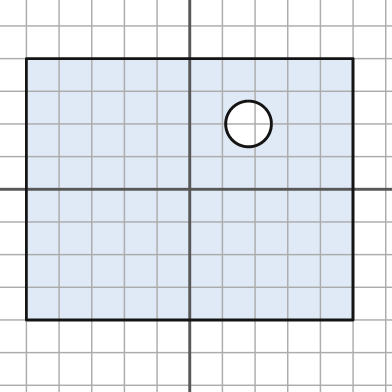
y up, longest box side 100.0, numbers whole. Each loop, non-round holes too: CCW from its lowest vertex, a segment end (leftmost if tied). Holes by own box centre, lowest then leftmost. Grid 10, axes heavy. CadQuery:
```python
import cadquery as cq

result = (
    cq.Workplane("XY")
    .moveTo(-50.0, -40.0)
    .lineTo(50.0, -40.0)
    .lineTo(50.0, 40.0)
    .lineTo(-50.0, 40.0)
    .close()
    .moveTo(18.0, 20.0)
    .circle(7.0)
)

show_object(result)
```